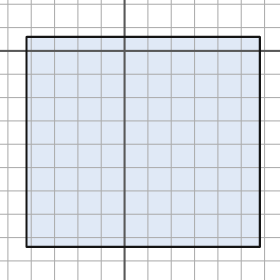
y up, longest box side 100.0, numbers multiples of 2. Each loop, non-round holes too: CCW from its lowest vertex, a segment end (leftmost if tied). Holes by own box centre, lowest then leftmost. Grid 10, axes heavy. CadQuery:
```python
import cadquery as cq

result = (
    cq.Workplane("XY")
    .moveTo(-42.0, -84.0)
    .lineTo(58.0, -84.0)
    .lineTo(58.0, 6.0)
    .lineTo(-42.0, 6.0)
    .close()
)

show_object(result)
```